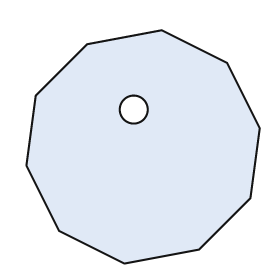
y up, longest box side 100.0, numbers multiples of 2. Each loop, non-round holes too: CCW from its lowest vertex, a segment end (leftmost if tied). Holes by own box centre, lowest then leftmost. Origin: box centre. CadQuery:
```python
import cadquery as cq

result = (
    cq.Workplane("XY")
    .moveTo(-8.0, -50.0)
    .lineTo(24.0, -44.0)
    .lineTo(46.0, -22.0)
    .lineTo(50.0, 8.0)
    .lineTo(36.0, 36.0)
    .lineTo(8.0, 50.0)
    .lineTo(-24.0, 44.0)
    .lineTo(-46.0, 22.0)
    .lineTo(-50.0, -8.0)
    .lineTo(-36.0, -36.0)
    .close()
    .moveTo(-4.0, 16.0)
    .circle(6.0)
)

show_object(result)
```